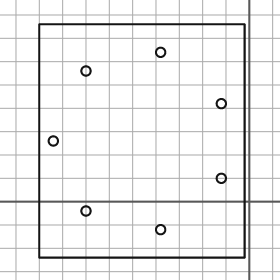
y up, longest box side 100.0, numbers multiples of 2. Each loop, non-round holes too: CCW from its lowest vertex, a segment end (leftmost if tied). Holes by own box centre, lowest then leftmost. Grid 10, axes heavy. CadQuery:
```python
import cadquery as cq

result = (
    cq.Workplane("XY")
    .moveTo(-90.0, -24.0)
    .lineTo(-2.0, -24.0)
    .lineTo(-2.0, 76.0)
    .lineTo(-90.0, 76.0)
    .close()
    .moveTo(-38.0, -12.0)
    .circle(2.0)
    .moveTo(-70.0, -4.0)
    .circle(2.0)
    .moveTo(-12.0, 10.0)
    .circle(2.0)
    .moveTo(-84.0, 26.0)
    .circle(2.0)
    .moveTo(-12.0, 42.0)
    .circle(2.0)
    .moveTo(-70.0, 56.0)
    .circle(2.0)
    .moveTo(-38.0, 64.0)
    .circle(2.0)
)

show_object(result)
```